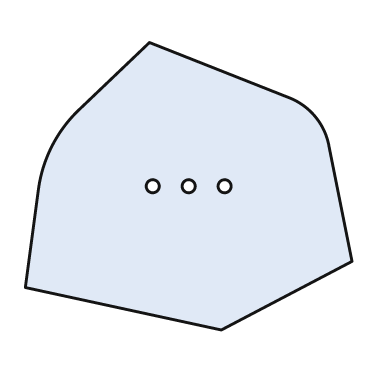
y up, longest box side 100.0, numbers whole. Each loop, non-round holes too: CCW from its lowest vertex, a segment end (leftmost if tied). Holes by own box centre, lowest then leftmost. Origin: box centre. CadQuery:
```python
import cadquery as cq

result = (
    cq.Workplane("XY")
    .moveTo(10.0, -44.0)
    .lineTo(50.0, -23.0)
    .lineTo(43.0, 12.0)
    .threePointArc((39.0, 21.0), (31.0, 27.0))
    .lineTo(-12.0, 44.0)
    .lineTo(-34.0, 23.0)
    .threePointArc((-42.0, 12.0), (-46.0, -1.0))
    .lineTo(-50.0, -31.0)
    .close()
    .moveTo(-11.0, 0.0)
    .circle(2.0)
    .moveTo(0.0, 0.0)
    .circle(2.0)
    .moveTo(11.0, 0.0)
    .circle(2.0)
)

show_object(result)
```